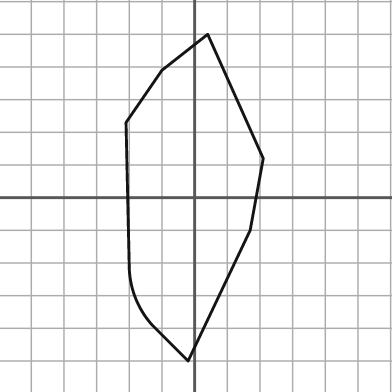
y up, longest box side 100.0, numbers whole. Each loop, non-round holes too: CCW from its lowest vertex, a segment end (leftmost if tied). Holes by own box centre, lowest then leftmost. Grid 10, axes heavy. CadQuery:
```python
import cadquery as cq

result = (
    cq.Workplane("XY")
    .moveTo(-2.0, -50.0)
    .lineTo(17.0, -10.0)
    .lineTo(21.0, 12.0)
    .lineTo(4.0, 50.0)
    .lineTo(-10.0, 39.0)
    .lineTo(-21.0, 23.0)
    .lineTo(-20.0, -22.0)
    .threePointArc((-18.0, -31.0), (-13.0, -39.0))
    .close()
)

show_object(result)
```